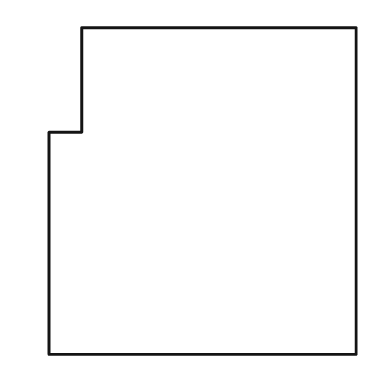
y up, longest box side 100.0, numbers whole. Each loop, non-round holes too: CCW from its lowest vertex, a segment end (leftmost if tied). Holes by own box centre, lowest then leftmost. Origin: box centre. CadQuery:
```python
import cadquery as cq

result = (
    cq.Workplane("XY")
    .moveTo(-47.0, -50.0)
    .lineTo(47.0, -50.0)
    .lineTo(47.0, 50.0)
    .lineTo(-37.0, 50.0)
    .lineTo(-37.0, 18.0)
    .lineTo(-47.0, 18.0)
    .close()
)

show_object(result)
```